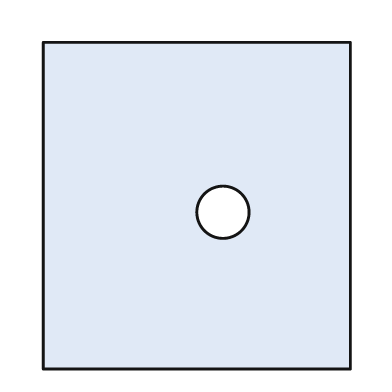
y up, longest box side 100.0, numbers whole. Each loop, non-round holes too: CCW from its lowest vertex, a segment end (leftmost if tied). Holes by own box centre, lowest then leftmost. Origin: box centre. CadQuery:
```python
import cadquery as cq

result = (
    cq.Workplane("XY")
    .moveTo(-47.0, -50.0)
    .lineTo(47.0, -50.0)
    .lineTo(47.0, 50.0)
    .lineTo(-47.0, 50.0)
    .close()
    .moveTo(8.0, -2.0)
    .circle(8.0)
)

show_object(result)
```